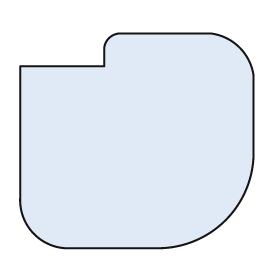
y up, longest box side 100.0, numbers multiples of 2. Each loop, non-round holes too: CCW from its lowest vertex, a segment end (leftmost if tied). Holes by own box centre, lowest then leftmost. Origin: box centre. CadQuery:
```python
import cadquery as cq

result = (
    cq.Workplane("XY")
    .moveTo(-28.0, -46.0)
    .lineTo(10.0, -46.0)
    .threePointArc((38.0, -34.0), (50.0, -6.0))
    .lineTo(50.0, 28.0)
    .threePointArc((44.0, 40.0), (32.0, 46.0))
    .lineTo(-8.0, 46.0)
    .threePointArc((-12.0, 44.0), (-14.0, 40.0))
    .lineTo(-14.0, 32.0)
    .lineTo(-50.0, 32.0)
    .lineTo(-50.0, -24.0)
    .threePointArc((-44.0, -40.0), (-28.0, -46.0))
    .close()
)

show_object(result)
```